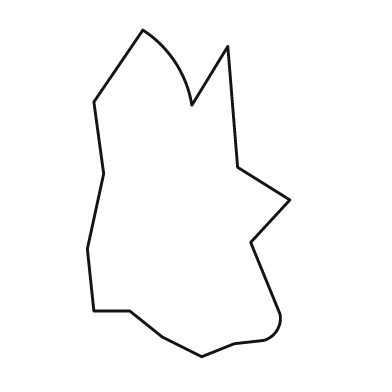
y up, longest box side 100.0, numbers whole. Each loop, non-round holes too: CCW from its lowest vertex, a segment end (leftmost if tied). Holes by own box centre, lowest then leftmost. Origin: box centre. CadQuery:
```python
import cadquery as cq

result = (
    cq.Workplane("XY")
    .moveTo(4.0, -50.0)
    .lineTo(14.0, -46.0)
    .lineTo(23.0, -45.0)
    .threePointArc((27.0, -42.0), (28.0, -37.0))
    .lineTo(19.0, -15.0)
    .lineTo(31.0, -2.0)
    .lineTo(15.0, 8.0)
    .lineTo(12.0, 45.0)
    .lineTo(1.0, 27.0)
    .threePointArc((-4.0, 40.0), (-14.0, 50.0))
    .lineTo(-29.0, 28.0)
    .lineTo(-26.0, 6.0)
    .lineTo(-31.0, -17.0)
    .lineTo(-29.0, -36.0)
    .lineTo(-18.0, -36.0)
    .lineTo(-8.0, -44.0)
    .close()
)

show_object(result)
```